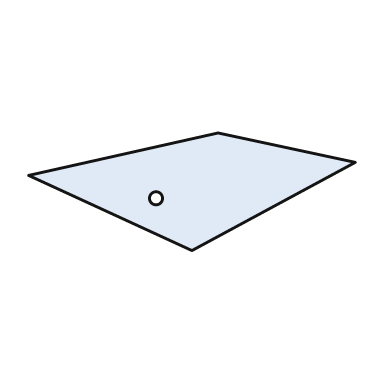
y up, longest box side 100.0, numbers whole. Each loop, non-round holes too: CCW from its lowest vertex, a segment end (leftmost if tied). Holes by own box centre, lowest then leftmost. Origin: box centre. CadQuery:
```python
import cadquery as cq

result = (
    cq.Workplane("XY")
    .moveTo(0.0, -18.0)
    .lineTo(50.0, 9.0)
    .lineTo(8.0, 18.0)
    .lineTo(-50.0, 5.0)
    .close()
    .moveTo(-11.0, -2.0)
    .circle(2.0)
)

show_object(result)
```